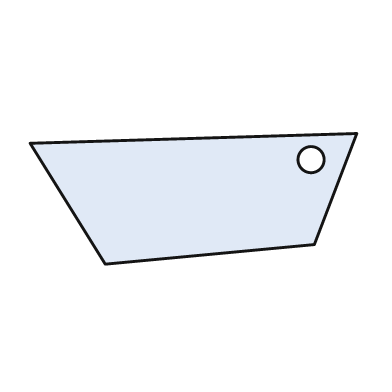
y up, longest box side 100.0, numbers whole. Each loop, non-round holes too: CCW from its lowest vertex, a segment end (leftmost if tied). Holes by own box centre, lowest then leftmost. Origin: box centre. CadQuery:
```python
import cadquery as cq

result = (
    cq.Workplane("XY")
    .moveTo(-27.0, -20.0)
    .lineTo(37.0, -14.0)
    .lineTo(50.0, 20.0)
    .lineTo(-50.0, 17.0)
    .close()
    .moveTo(36.0, 12.0)
    .circle(4.0)
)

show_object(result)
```